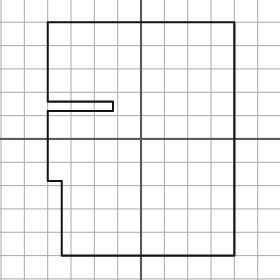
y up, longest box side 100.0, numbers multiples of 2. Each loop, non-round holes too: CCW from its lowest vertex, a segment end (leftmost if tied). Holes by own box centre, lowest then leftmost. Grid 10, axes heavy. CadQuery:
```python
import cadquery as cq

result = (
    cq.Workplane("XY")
    .moveTo(-34.0, -50.0)
    .lineTo(40.0, -50.0)
    .lineTo(40.0, 50.0)
    .lineTo(-40.0, 50.0)
    .lineTo(-40.0, 16.0)
    .lineTo(-12.0, 16.0)
    .lineTo(-12.0, 12.0)
    .lineTo(-40.0, 12.0)
    .lineTo(-40.0, -18.0)
    .lineTo(-34.0, -18.0)
    .close()
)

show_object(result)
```